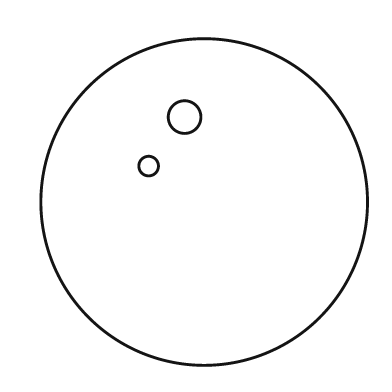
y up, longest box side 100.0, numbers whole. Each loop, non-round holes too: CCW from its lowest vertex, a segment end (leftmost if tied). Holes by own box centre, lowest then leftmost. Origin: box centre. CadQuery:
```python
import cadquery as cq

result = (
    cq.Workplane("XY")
    .moveTo(0.0, 0.0)
    .circle(50.0)
    .moveTo(-17.0, 11.0)
    .circle(3.0)
    .moveTo(-6.0, 26.0)
    .circle(5.0)
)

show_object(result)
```